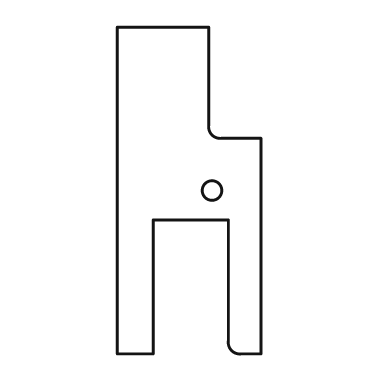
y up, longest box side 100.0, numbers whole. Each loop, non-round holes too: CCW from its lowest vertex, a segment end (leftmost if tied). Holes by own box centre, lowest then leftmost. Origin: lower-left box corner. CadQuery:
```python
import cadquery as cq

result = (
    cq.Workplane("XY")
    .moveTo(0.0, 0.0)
    .lineTo(11.0, 0.0)
    .lineTo(11.0, 41.0)
    .lineTo(34.0, 41.0)
    .lineTo(34.0, 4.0)
    .threePointArc((35.0, 1.0), (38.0, 0.0))
    .lineTo(44.0, 0.0)
    .lineTo(44.0, 66.0)
    .lineTo(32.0, 66.0)
    .threePointArc((29.0, 67.0), (28.0, 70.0))
    .lineTo(28.0, 100.0)
    .lineTo(0.0, 100.0)
    .close()
    .moveTo(29.0, 50.0)
    .circle(3.0)
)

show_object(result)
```